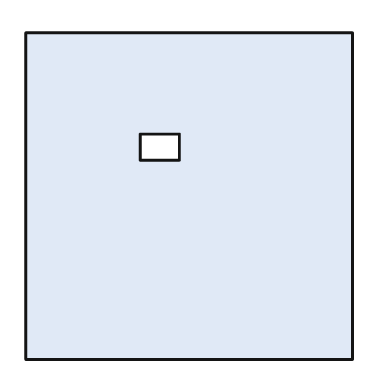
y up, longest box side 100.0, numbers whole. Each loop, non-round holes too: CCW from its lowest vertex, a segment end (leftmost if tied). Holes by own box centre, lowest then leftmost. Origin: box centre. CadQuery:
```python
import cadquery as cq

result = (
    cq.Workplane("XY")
    .moveTo(-50.0, -50.0)
    .lineTo(50.0, -50.0)
    .lineTo(50.0, 50.0)
    .lineTo(-50.0, 50.0)
    .close()
    .moveTo(-15.0, 11.0)
    .lineTo(-3.0, 11.0)
    .lineTo(-3.0, 19.0)
    .lineTo(-15.0, 19.0)
    .close()
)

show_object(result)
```